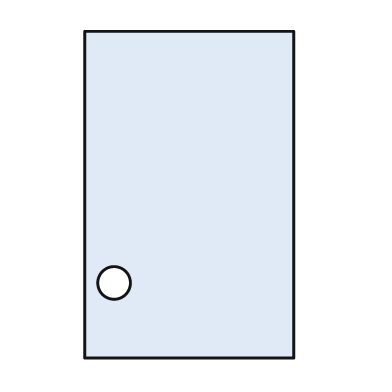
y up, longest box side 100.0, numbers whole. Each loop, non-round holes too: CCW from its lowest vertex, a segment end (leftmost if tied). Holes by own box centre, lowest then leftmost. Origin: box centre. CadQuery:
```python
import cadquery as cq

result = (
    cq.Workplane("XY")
    .moveTo(-32.0, -50.0)
    .lineTo(32.0, -50.0)
    .lineTo(32.0, 50.0)
    .lineTo(-32.0, 50.0)
    .close()
    .moveTo(-23.0, -27.0)
    .circle(5.0)
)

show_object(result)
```